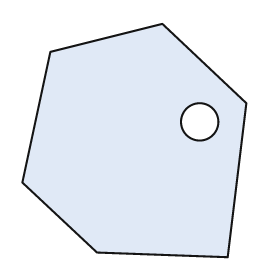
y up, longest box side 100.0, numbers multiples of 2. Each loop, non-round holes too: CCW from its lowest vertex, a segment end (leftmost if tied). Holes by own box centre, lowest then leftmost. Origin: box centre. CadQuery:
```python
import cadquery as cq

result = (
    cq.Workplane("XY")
    .moveTo(40.0, -50.0)
    .lineTo(48.0, 16.0)
    .lineTo(12.0, 50.0)
    .lineTo(-36.0, 38.0)
    .lineTo(-48.0, -18.0)
    .lineTo(-16.0, -48.0)
    .close()
    .moveTo(28.0, 8.0)
    .circle(8.0)
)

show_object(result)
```